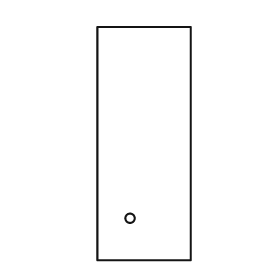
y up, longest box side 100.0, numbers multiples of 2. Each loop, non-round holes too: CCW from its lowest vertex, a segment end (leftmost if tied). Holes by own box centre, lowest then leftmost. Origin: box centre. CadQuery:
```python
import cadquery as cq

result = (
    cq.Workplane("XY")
    .moveTo(-20.0, -50.0)
    .lineTo(20.0, -50.0)
    .lineTo(20.0, 50.0)
    .lineTo(-20.0, 50.0)
    .close()
    .moveTo(-6.0, -32.0)
    .circle(2.0)
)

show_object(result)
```